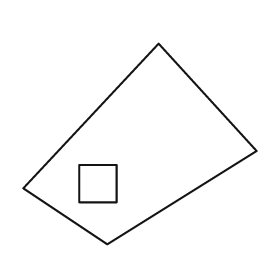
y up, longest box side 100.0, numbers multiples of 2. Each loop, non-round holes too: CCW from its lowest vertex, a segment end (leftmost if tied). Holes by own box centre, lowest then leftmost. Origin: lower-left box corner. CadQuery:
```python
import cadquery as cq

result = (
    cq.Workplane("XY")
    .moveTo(36.0, 0.0)
    .lineTo(100.0, 40.0)
    .lineTo(58.0, 86.0)
    .lineTo(0.0, 24.0)
    .close()
    .moveTo(24.0, 18.0)
    .lineTo(40.0, 18.0)
    .lineTo(40.0, 34.0)
    .lineTo(24.0, 34.0)
    .close()
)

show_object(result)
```